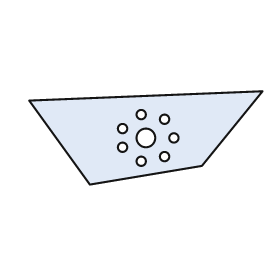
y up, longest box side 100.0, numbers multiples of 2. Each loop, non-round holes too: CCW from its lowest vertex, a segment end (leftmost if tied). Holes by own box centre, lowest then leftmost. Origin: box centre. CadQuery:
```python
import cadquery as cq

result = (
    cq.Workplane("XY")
    .moveTo(-24.0, -20.0)
    .lineTo(24.0, -12.0)
    .lineTo(50.0, 20.0)
    .lineTo(-50.0, 16.0)
    .close()
    .moveTo(-2.0, -10.0)
    .circle(2.0)
    .moveTo(8.0, -8.0)
    .circle(2.0)
    .moveTo(-10.0, -4.0)
    .circle(2.0)
    .moveTo(0.0, 0.0)
    .circle(4.0)
    .moveTo(12.0, 0.0)
    .circle(2.0)
    .moveTo(-10.0, 4.0)
    .circle(2.0)
    .moveTo(8.0, 8.0)
    .circle(2.0)
    .moveTo(-2.0, 10.0)
    .circle(2.0)
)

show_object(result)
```